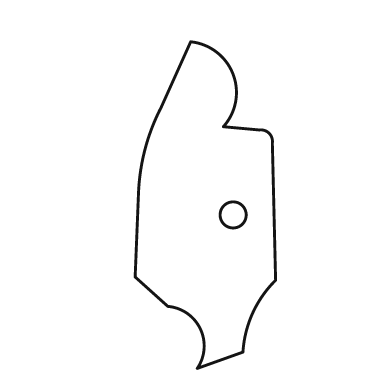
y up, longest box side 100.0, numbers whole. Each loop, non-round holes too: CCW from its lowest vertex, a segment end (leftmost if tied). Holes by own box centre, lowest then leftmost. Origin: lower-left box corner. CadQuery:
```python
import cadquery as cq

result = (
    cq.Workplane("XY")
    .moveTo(19.0, 0.0)
    .lineTo(33.0, 5.0)
    .threePointArc((36.0, 17.0), (43.0, 27.0))
    .lineTo(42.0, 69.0)
    .threePointArc((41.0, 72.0), (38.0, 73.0))
    .lineTo(27.0, 74.0)
    .threePointArc((30.0, 90.0), (17.0, 100.0))
    .lineTo(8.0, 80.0)
    .threePointArc((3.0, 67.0), (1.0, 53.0))
    .lineTo(0.0, 28.0)
    .lineTo(10.0, 19.0)
    .threePointArc((20.0, 12.0), (19.0, 0.0))
    .close()
    .moveTo(30.0, 47.0)
    .circle(4.0)
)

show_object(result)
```